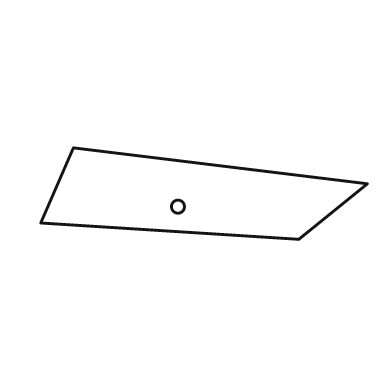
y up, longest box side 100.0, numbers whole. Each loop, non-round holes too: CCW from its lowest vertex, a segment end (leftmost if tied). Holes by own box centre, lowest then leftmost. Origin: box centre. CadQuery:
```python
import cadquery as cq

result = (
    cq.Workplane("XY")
    .moveTo(29.0, -14.0)
    .lineTo(50.0, 3.0)
    .lineTo(-40.0, 14.0)
    .lineTo(-50.0, -9.0)
    .close()
    .moveTo(-8.0, -4.0)
    .circle(2.0)
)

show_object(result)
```